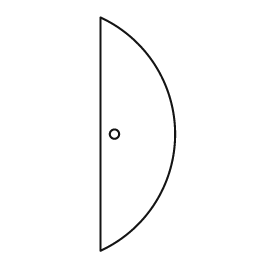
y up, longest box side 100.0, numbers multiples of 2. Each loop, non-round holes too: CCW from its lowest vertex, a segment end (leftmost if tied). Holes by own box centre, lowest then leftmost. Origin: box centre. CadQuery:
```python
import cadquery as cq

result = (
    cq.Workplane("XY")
    .moveTo(-16.0, -50.0)
    .threePointArc((16.0, 0.0), (-16.0, 50.0))
    .close()
    .moveTo(-10.0, 0.0)
    .circle(2.0)
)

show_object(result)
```